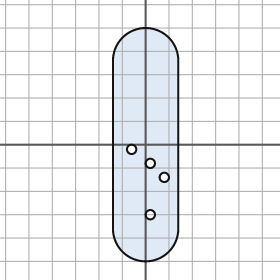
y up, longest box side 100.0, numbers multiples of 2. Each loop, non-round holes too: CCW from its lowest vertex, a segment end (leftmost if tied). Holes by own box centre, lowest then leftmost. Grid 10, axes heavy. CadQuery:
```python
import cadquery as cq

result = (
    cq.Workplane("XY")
    .moveTo(-14.0, -36.0)
    .threePointArc((0.0, -50.0), (14.0, -36.0))
    .lineTo(14.0, 36.0)
    .threePointArc((0.0, 50.0), (-14.0, 36.0))
    .close()
    .moveTo(2.0, -30.0)
    .circle(2.0)
    .moveTo(8.0, -14.0)
    .circle(2.0)
    .moveTo(2.0, -8.0)
    .circle(2.0)
    .moveTo(-6.0, -2.0)
    .circle(2.0)
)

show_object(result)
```